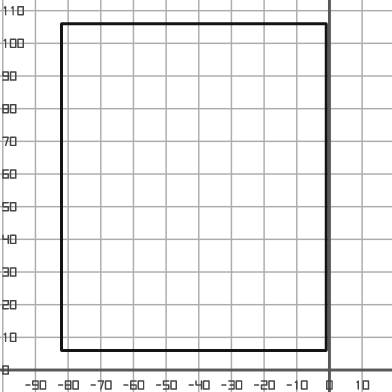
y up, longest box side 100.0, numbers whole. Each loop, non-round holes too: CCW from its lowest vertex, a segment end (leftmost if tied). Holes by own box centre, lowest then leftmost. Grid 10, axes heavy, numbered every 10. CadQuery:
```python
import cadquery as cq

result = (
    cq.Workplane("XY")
    .moveTo(-82.0, 6.0)
    .lineTo(-1.0, 6.0)
    .lineTo(-1.0, 106.0)
    .lineTo(-82.0, 106.0)
    .close()
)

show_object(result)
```